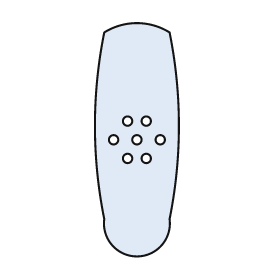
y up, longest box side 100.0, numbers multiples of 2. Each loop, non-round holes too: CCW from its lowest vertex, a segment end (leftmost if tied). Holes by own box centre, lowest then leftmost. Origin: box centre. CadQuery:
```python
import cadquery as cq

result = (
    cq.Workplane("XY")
    .moveTo(-14.0, -34.0)
    .threePointArc((0.0, -50.0), (14.0, -34.0))
    .threePointArc((18.0, 6.0), (14.0, 46.0))
    .threePointArc((0.0, 50.0), (-14.0, 46.0))
    .threePointArc((-18.0, 6.0), (-14.0, -34.0))
    .close()
    .moveTo(-4.0, -8.0)
    .circle(2.0)
    .moveTo(4.0, -8.0)
    .circle(2.0)
    .moveTo(-10.0, 0.0)
    .circle(2.0)
    .moveTo(0.0, 0.0)
    .circle(2.0)
    .moveTo(10.0, 0.0)
    .circle(2.0)
    .moveTo(-4.0, 8.0)
    .circle(2.0)
    .moveTo(4.0, 8.0)
    .circle(2.0)
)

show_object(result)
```